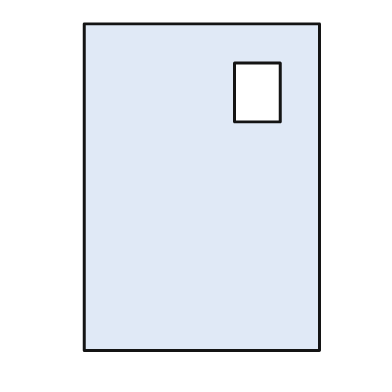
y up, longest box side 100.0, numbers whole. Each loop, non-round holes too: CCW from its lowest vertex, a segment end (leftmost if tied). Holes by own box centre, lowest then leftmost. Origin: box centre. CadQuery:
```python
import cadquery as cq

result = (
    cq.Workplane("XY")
    .moveTo(-36.0, -50.0)
    .lineTo(36.0, -50.0)
    .lineTo(36.0, 50.0)
    .lineTo(-36.0, 50.0)
    .close()
    .moveTo(10.0, 20.0)
    .lineTo(24.0, 20.0)
    .lineTo(24.0, 38.0)
    .lineTo(10.0, 38.0)
    .close()
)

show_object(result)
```